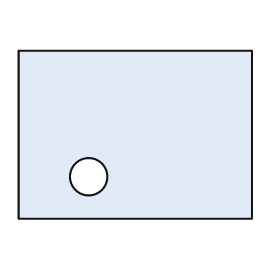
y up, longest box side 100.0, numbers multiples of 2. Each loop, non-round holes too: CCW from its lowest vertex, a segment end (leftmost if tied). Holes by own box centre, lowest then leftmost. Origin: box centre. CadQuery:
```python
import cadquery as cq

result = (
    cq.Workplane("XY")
    .moveTo(-50.0, -36.0)
    .lineTo(50.0, -36.0)
    .lineTo(50.0, 36.0)
    .lineTo(-50.0, 36.0)
    .close()
    .moveTo(-20.0, -18.0)
    .circle(8.0)
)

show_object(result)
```